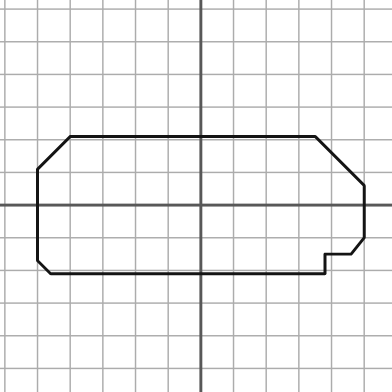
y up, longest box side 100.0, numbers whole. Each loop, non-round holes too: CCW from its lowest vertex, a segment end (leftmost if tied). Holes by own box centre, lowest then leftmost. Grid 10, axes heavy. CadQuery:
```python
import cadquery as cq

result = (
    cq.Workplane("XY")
    .moveTo(-46.0, -21.0)
    .lineTo(38.0, -21.0)
    .lineTo(38.0, -15.0)
    .lineTo(46.0, -15.0)
    .lineTo(50.0, -10.0)
    .lineTo(50.0, 6.0)
    .lineTo(35.0, 21.0)
    .lineTo(-40.0, 21.0)
    .lineTo(-50.0, 11.0)
    .lineTo(-50.0, -17.0)
    .close()
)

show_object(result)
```